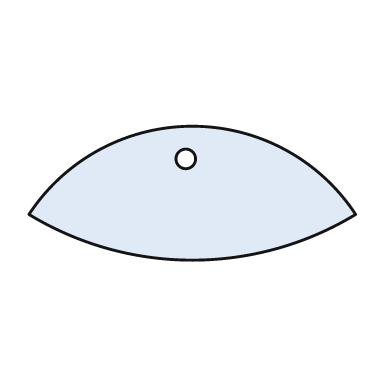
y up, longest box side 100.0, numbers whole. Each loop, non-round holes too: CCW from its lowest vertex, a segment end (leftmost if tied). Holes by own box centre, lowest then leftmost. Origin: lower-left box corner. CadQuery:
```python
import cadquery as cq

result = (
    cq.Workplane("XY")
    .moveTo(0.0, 14.0)
    .threePointArc((50.0, 0.0), (100.0, 14.0))
    .threePointArc((50.0, 41.0), (0.0, 14.0))
    .close()
    .moveTo(48.0, 31.0)
    .circle(3.0)
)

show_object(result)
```